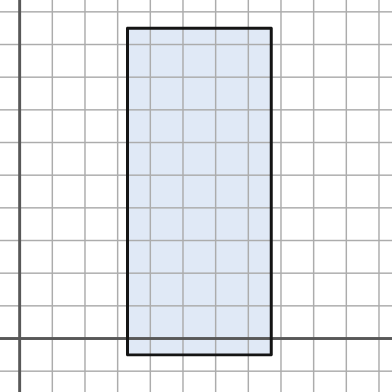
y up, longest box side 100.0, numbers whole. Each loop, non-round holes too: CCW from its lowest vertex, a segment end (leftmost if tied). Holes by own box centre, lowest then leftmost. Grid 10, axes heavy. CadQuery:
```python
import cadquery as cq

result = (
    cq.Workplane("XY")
    .moveTo(33.0, -5.0)
    .lineTo(77.0, -5.0)
    .lineTo(77.0, 95.0)
    .lineTo(33.0, 95.0)
    .close()
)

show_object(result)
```